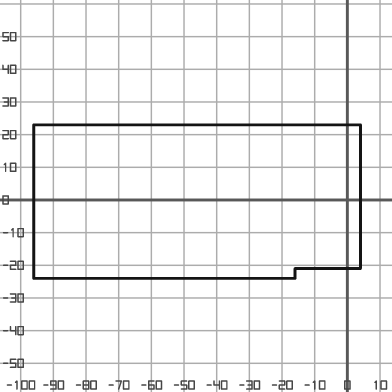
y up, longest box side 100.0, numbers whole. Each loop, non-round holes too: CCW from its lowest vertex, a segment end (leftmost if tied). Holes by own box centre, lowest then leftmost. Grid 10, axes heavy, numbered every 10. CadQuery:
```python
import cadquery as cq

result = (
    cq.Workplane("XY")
    .moveTo(-96.0, -24.0)
    .lineTo(-16.0, -24.0)
    .lineTo(-16.0, -21.0)
    .lineTo(4.0, -21.0)
    .lineTo(4.0, 23.0)
    .lineTo(-96.0, 23.0)
    .close()
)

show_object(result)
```